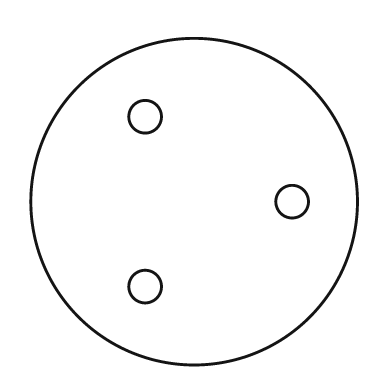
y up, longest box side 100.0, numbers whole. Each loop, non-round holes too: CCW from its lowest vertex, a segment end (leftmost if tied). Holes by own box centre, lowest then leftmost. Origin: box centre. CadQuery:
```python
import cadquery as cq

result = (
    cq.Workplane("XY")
    .moveTo(0.0, 0.0)
    .circle(50.0)
    .moveTo(-15.0, -26.0)
    .circle(5.0)
    .moveTo(30.0, 0.0)
    .circle(5.0)
    .moveTo(-15.0, 26.0)
    .circle(5.0)
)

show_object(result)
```